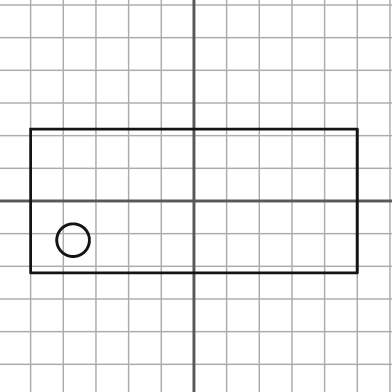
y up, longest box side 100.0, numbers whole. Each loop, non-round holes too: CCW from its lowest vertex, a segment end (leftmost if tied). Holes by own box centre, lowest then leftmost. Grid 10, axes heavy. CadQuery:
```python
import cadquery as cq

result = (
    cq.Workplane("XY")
    .moveTo(-50.0, -22.0)
    .lineTo(50.0, -22.0)
    .lineTo(50.0, 22.0)
    .lineTo(-50.0, 22.0)
    .close()
    .moveTo(-37.0, -12.0)
    .circle(5.0)
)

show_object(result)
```